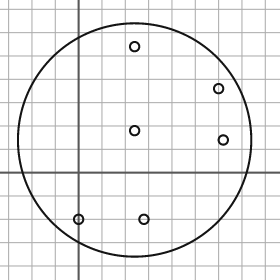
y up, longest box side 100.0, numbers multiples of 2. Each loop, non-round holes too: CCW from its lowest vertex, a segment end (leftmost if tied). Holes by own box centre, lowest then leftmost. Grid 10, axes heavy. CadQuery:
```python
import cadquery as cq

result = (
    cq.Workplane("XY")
    .moveTo(24.0, 14.0)
    .circle(50.0)
    .moveTo(0.0, -20.0)
    .circle(2.0)
    .moveTo(28.0, -20.0)
    .circle(2.0)
    .moveTo(62.0, 14.0)
    .circle(2.0)
    .moveTo(24.0, 18.0)
    .circle(2.0)
    .moveTo(60.0, 36.0)
    .circle(2.0)
    .moveTo(24.0, 54.0)
    .circle(2.0)
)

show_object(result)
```